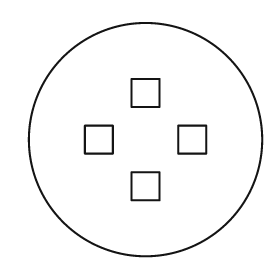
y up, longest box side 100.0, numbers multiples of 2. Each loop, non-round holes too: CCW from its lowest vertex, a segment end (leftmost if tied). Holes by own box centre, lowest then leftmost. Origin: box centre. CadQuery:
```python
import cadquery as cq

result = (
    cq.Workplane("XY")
    .moveTo(0.0, 0.0)
    .circle(50.0)
    .moveTo(-6.0, -26.0)
    .lineTo(6.0, -26.0)
    .lineTo(6.0, -14.0)
    .lineTo(-6.0, -14.0)
    .close()
    .moveTo(-26.0, -6.0)
    .lineTo(-14.0, -6.0)
    .lineTo(-14.0, 6.0)
    .lineTo(-26.0, 6.0)
    .close()
    .moveTo(14.0, -6.0)
    .lineTo(26.0, -6.0)
    .lineTo(26.0, 6.0)
    .lineTo(14.0, 6.0)
    .close()
    .moveTo(-6.0, 14.0)
    .lineTo(6.0, 14.0)
    .lineTo(6.0, 26.0)
    .lineTo(-6.0, 26.0)
    .close()
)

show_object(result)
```